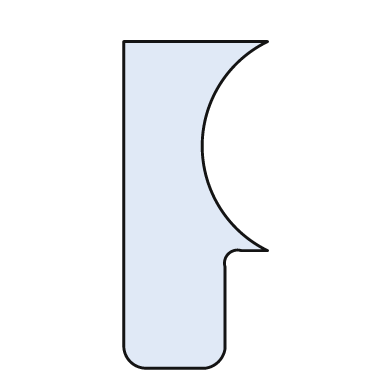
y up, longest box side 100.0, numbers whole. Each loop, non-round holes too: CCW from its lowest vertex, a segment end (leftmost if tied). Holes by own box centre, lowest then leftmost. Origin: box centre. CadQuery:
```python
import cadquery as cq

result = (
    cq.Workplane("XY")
    .moveTo(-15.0, -50.0)
    .lineTo(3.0, -50.0)
    .threePointArc((7.0, -48.0), (9.0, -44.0))
    .lineTo(9.0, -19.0)
    .threePointArc((10.0, -15.0), (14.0, -14.0))
    .lineTo(22.0, -14.0)
    .threePointArc((2.0, 18.0), (22.0, 50.0))
    .lineTo(-22.0, 50.0)
    .lineTo(-22.0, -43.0)
    .threePointArc((-20.0, -48.0), (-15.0, -50.0))
    .close()
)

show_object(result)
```